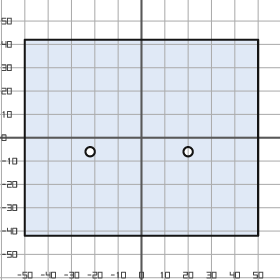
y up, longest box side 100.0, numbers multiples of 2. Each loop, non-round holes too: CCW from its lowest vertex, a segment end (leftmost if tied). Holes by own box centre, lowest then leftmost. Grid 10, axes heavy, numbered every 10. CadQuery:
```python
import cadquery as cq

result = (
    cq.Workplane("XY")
    .moveTo(-50.0, -42.0)
    .lineTo(50.0, -42.0)
    .lineTo(50.0, 42.0)
    .lineTo(-50.0, 42.0)
    .close()
    .moveTo(-22.0, -6.0)
    .circle(2.0)
    .moveTo(20.0, -6.0)
    .circle(2.0)
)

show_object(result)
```